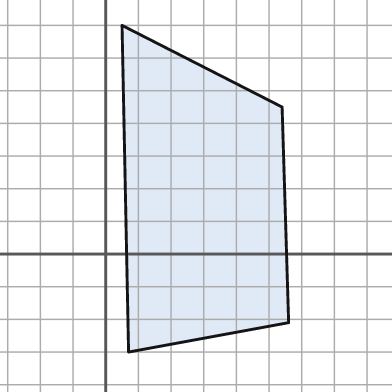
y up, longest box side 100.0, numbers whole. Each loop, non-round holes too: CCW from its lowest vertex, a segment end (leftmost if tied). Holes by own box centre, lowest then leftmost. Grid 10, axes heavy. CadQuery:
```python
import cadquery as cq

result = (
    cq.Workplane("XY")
    .moveTo(7.0, -30.0)
    .lineTo(56.0, -21.0)
    .lineTo(54.0, 45.0)
    .lineTo(5.0, 70.0)
    .close()
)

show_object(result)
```